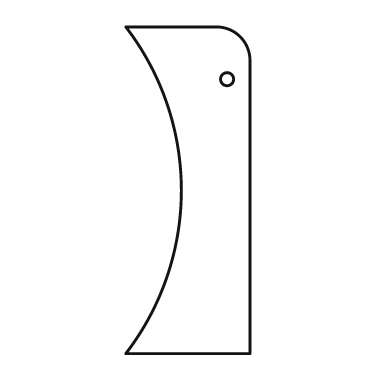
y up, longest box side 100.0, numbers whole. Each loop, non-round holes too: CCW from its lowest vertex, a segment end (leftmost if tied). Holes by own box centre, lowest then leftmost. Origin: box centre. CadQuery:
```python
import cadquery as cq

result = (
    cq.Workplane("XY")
    .moveTo(-19.0, -50.0)
    .lineTo(19.0, -50.0)
    .lineTo(19.0, 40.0)
    .threePointArc((16.0, 47.0), (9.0, 50.0))
    .lineTo(-19.0, 50.0)
    .threePointArc((-2.0, 0.0), (-19.0, -50.0))
    .close()
    .moveTo(12.0, 34.0)
    .circle(2.0)
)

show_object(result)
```